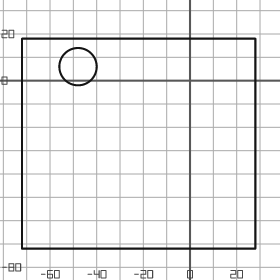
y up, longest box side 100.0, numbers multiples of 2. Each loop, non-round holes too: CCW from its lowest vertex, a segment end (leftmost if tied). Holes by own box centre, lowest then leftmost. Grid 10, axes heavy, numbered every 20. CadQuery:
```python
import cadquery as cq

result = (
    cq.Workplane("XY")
    .moveTo(-72.0, -72.0)
    .lineTo(28.0, -72.0)
    .lineTo(28.0, 18.0)
    .lineTo(-72.0, 18.0)
    .close()
    .moveTo(-48.0, 6.0)
    .circle(8.0)
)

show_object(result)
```